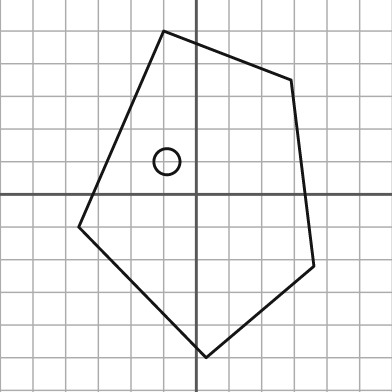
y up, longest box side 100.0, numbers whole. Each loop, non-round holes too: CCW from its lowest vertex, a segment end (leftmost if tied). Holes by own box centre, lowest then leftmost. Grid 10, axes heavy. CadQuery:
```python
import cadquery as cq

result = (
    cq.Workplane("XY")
    .moveTo(3.0, -50.0)
    .lineTo(36.0, -22.0)
    .lineTo(29.0, 35.0)
    .lineTo(-10.0, 50.0)
    .lineTo(-36.0, -10.0)
    .close()
    .moveTo(-9.0, 10.0)
    .circle(4.0)
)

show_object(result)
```